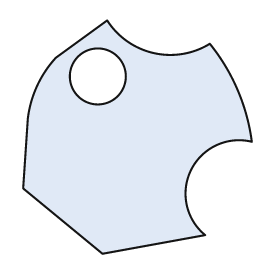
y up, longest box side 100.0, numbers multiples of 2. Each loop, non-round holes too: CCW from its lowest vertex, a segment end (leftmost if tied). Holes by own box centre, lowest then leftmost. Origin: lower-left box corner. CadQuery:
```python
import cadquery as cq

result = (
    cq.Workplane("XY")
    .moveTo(34.0, 0.0)
    .lineTo(78.0, 8.0)
    .threePointArc((72.0, 36.0), (98.0, 48.0))
    .threePointArc((92.0, 70.0), (80.0, 90.0))
    .threePointArc((56.0, 86.0), (36.0, 100.0))
    .lineTo(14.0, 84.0)
    .threePointArc((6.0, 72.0), (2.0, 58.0))
    .lineTo(0.0, 28.0)
    .close()
    .moveTo(32.0, 76.0)
    .circle(12.0)
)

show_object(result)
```